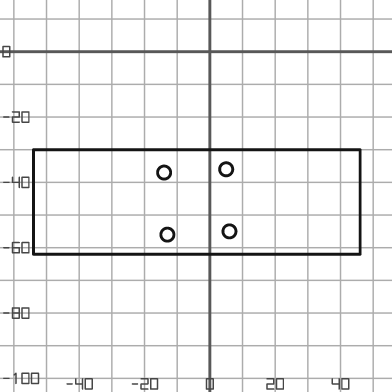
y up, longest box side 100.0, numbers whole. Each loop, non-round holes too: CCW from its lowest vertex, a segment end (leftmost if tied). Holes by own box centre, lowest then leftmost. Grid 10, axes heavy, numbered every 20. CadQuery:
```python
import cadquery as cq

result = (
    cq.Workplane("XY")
    .moveTo(-54.0, -62.0)
    .lineTo(46.0, -62.0)
    .lineTo(46.0, -30.0)
    .lineTo(-54.0, -30.0)
    .close()
    .moveTo(-13.0, -56.0)
    .circle(2.0)
    .moveTo(6.0, -55.0)
    .circle(2.0)
    .moveTo(-14.0, -37.0)
    .circle(2.0)
    .moveTo(5.0, -36.0)
    .circle(2.0)
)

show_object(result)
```